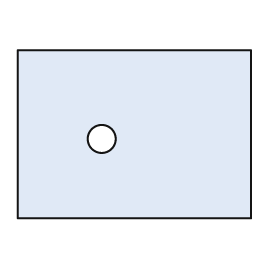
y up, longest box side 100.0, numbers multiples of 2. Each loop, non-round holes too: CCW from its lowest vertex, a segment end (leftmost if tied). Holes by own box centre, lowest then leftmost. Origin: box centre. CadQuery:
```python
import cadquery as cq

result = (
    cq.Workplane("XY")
    .moveTo(-50.0, -36.0)
    .lineTo(50.0, -36.0)
    .lineTo(50.0, 36.0)
    .lineTo(-50.0, 36.0)
    .close()
    .moveTo(-14.0, -2.0)
    .circle(6.0)
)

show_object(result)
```